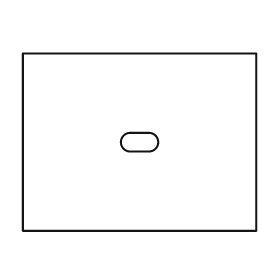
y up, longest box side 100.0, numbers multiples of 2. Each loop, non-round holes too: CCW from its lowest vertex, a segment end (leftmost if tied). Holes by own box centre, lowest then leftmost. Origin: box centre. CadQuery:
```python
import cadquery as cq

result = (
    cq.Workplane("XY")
    .moveTo(-50.0, -38.0)
    .lineTo(50.0, -38.0)
    .lineTo(50.0, 38.0)
    .lineTo(-50.0, 38.0)
    .close()
    .moveTo(-4.0, -4.0)
    .lineTo(4.0, -4.0)
    .threePointArc((8.0, 0.0), (4.0, 4.0))
    .lineTo(-4.0, 4.0)
    .threePointArc((-8.0, 0.0), (-4.0, -4.0))
    .close()
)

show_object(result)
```